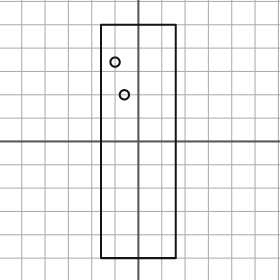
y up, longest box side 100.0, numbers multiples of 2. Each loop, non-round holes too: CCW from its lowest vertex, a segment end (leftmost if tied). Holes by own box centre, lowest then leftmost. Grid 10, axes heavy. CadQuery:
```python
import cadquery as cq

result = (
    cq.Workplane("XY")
    .moveTo(-16.0, -50.0)
    .lineTo(16.0, -50.0)
    .lineTo(16.0, 50.0)
    .lineTo(-16.0, 50.0)
    .close()
    .moveTo(-6.0, 20.0)
    .circle(2.0)
    .moveTo(-10.0, 34.0)
    .circle(2.0)
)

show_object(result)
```